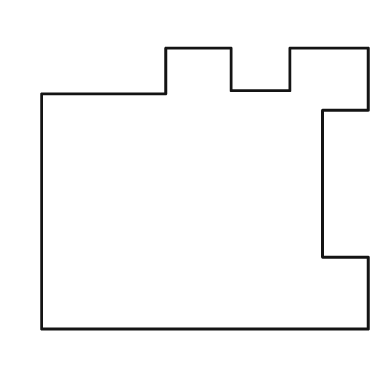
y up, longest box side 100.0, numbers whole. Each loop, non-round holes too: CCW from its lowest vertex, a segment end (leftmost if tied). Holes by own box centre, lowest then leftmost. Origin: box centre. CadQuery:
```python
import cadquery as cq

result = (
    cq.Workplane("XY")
    .moveTo(-50.0, -43.0)
    .lineTo(50.0, -43.0)
    .lineTo(50.0, -21.0)
    .lineTo(36.0, -21.0)
    .lineTo(36.0, 24.0)
    .lineTo(50.0, 24.0)
    .lineTo(50.0, 43.0)
    .lineTo(26.0, 43.0)
    .lineTo(26.0, 30.0)
    .lineTo(8.0, 30.0)
    .lineTo(8.0, 43.0)
    .lineTo(-12.0, 43.0)
    .lineTo(-12.0, 29.0)
    .lineTo(-50.0, 29.0)
    .close()
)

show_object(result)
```